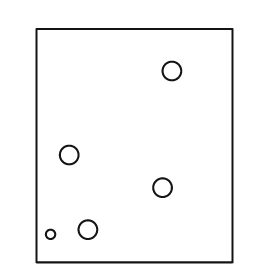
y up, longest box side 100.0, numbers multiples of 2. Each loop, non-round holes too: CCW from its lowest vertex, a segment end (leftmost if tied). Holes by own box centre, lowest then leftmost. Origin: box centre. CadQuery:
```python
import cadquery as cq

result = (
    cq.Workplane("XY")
    .moveTo(-42.0, -50.0)
    .lineTo(42.0, -50.0)
    .lineTo(42.0, 50.0)
    .lineTo(-42.0, 50.0)
    .close()
    .moveTo(-36.0, -38.0)
    .circle(2.0)
    .moveTo(-20.0, -36.0)
    .circle(4.0)
    .moveTo(12.0, -18.0)
    .circle(4.0)
    .moveTo(-28.0, -4.0)
    .circle(4.0)
    .moveTo(16.0, 32.0)
    .circle(4.0)
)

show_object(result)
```